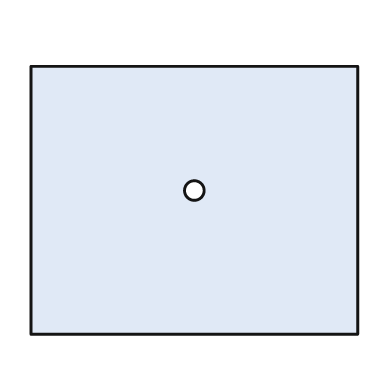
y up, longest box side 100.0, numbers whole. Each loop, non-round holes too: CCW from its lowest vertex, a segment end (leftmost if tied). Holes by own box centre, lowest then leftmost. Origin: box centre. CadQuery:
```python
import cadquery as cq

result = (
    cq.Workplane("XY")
    .moveTo(-50.0, -41.0)
    .lineTo(50.0, -41.0)
    .lineTo(50.0, 41.0)
    .lineTo(-50.0, 41.0)
    .close()
    .moveTo(0.0, 3.0)
    .circle(3.0)
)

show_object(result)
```